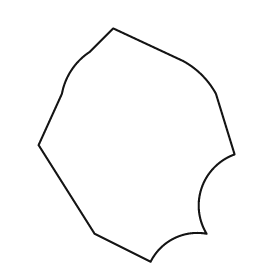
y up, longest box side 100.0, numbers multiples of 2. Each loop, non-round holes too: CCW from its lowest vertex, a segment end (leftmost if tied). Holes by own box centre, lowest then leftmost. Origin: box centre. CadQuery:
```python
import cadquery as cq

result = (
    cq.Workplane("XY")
    .moveTo(6.0, -50.0)
    .threePointArc((16.0, -40.0), (30.0, -38.0))
    .threePointArc((28.0, -18.0), (42.0, -4.0))
    .lineTo(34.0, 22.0)
    .threePointArc((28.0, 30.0), (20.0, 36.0))
    .lineTo(-10.0, 50.0)
    .lineTo(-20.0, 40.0)
    .threePointArc((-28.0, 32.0), (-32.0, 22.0))
    .lineTo(-42.0, 0.0)
    .lineTo(-18.0, -38.0)
    .close()
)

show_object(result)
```